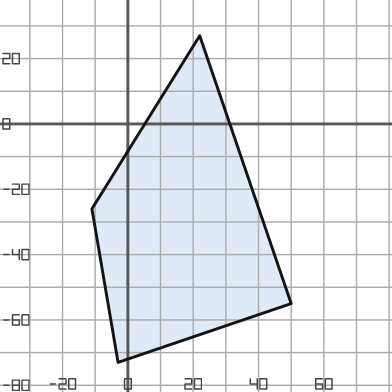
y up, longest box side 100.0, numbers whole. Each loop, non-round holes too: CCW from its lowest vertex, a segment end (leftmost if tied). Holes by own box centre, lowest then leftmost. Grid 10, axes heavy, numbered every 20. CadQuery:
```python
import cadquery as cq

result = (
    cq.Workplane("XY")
    .moveTo(-3.0, -73.0)
    .lineTo(50.0, -55.0)
    .lineTo(22.0, 27.0)
    .lineTo(-11.0, -26.0)
    .close()
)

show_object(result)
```